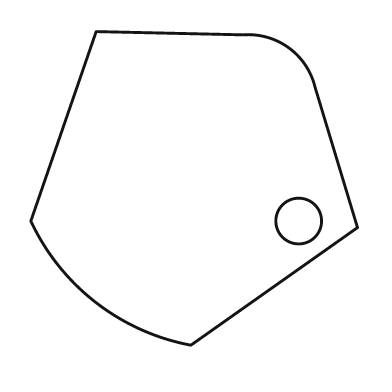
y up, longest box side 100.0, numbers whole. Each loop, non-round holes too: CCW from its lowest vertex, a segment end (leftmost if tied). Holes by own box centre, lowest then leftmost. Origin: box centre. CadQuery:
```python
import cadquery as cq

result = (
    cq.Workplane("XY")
    .moveTo(-1.0, -48.0)
    .lineTo(50.0, -12.0)
    .lineTo(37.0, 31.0)
    .threePointArc((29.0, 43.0), (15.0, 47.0))
    .lineTo(-30.0, 48.0)
    .lineTo(-50.0, -10.0)
    .threePointArc((-30.0, -35.0), (-1.0, -48.0))
    .close()
    .moveTo(32.0, -10.0)
    .circle(7.0)
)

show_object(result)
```